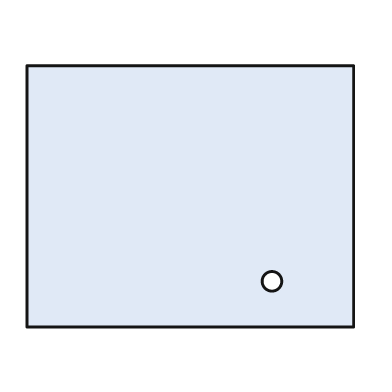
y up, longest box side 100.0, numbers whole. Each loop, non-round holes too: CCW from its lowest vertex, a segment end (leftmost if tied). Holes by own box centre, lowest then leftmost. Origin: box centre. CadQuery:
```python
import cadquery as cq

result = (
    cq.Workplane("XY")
    .moveTo(-50.0, -40.0)
    .lineTo(50.0, -40.0)
    .lineTo(50.0, 40.0)
    .lineTo(-50.0, 40.0)
    .close()
    .moveTo(25.0, -26.0)
    .circle(3.0)
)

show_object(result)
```